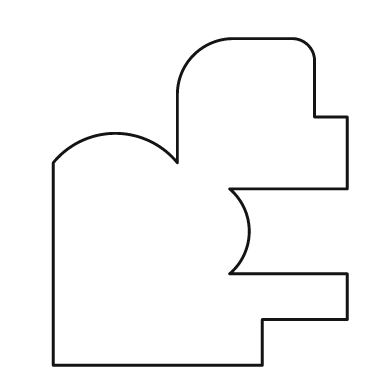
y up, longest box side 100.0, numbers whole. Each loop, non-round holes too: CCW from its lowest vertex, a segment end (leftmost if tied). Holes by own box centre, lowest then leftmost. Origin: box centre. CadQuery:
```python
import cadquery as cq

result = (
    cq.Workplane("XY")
    .moveTo(-45.0, -50.0)
    .lineTo(19.0, -50.0)
    .lineTo(19.0, -36.0)
    .lineTo(45.0, -36.0)
    .lineTo(45.0, -22.0)
    .lineTo(9.0, -22.0)
    .threePointArc((15.0, -9.0), (9.0, 4.0))
    .lineTo(45.0, 4.0)
    .lineTo(45.0, 26.0)
    .lineTo(35.0, 26.0)
    .lineTo(35.0, 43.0)
    .threePointArc((33.0, 48.0), (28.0, 50.0))
    .lineTo(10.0, 50.0)
    .threePointArc((-2.0, 45.0), (-7.0, 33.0))
    .lineTo(-7.0, 12.0)
    .threePointArc((-26.0, 21.0), (-45.0, 12.0))
    .close()
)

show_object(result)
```